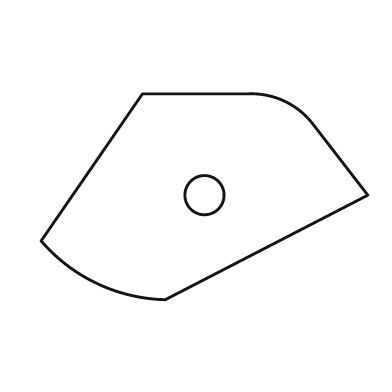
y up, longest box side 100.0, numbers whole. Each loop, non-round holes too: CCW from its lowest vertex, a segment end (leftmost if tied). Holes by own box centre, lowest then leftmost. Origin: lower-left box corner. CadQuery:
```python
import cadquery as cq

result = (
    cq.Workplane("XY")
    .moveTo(38.0, 0.0)
    .lineTo(100.0, 32.0)
    .lineTo(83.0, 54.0)
    .threePointArc((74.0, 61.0), (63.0, 63.0))
    .lineTo(31.0, 63.0)
    .lineTo(0.0, 18.0)
    .threePointArc((17.0, 5.0), (38.0, 0.0))
    .close()
    .moveTo(50.0, 32.0)
    .circle(6.0)
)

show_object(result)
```